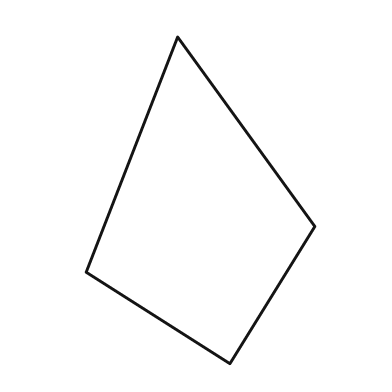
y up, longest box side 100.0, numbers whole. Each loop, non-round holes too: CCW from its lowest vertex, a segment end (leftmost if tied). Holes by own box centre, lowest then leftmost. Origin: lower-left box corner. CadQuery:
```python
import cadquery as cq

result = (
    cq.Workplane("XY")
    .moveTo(44.0, 0.0)
    .lineTo(70.0, 42.0)
    .lineTo(28.0, 100.0)
    .lineTo(0.0, 28.0)
    .close()
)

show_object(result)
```